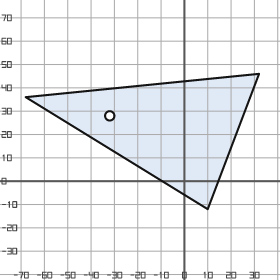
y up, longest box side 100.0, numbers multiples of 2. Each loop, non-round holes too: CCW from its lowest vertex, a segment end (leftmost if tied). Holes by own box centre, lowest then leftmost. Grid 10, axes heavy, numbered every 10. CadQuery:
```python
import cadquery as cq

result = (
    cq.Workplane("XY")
    .moveTo(10.0, -12.0)
    .lineTo(32.0, 46.0)
    .lineTo(-68.0, 36.0)
    .close()
    .moveTo(-32.0, 28.0)
    .circle(2.0)
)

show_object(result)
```